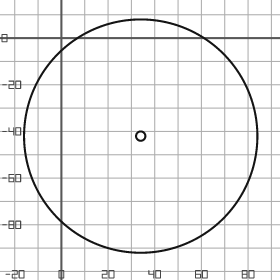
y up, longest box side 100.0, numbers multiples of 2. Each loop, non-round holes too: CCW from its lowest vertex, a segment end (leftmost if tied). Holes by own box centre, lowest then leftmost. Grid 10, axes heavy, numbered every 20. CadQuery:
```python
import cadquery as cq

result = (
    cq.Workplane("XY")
    .moveTo(34.0, -42.0)
    .circle(50.0)
    .moveTo(34.0, -42.0)
    .circle(2.0)
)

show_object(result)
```